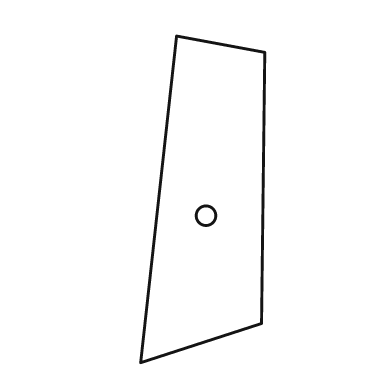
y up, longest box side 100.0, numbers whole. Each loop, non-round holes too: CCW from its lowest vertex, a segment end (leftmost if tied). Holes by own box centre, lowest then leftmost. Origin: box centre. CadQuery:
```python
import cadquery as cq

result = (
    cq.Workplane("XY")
    .moveTo(-19.0, -50.0)
    .lineTo(18.0, -38.0)
    .lineTo(19.0, 45.0)
    .lineTo(-8.0, 50.0)
    .close()
    .moveTo(1.0, -5.0)
    .circle(3.0)
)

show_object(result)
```